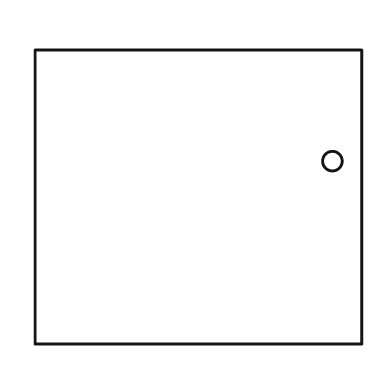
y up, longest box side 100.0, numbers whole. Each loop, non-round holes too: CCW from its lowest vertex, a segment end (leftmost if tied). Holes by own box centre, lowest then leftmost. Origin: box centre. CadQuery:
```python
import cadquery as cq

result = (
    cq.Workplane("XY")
    .moveTo(-50.0, -45.0)
    .lineTo(50.0, -45.0)
    .lineTo(50.0, 45.0)
    .lineTo(-50.0, 45.0)
    .close()
    .moveTo(41.0, 11.0)
    .circle(3.0)
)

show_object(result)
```